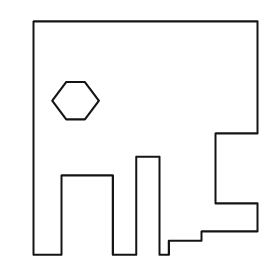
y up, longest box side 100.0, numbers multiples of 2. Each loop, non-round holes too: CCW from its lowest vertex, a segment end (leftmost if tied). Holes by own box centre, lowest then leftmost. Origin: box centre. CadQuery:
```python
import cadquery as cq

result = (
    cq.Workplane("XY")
    .moveTo(-48.0, -50.0)
    .lineTo(-36.0, -50.0)
    .lineTo(-36.0, -16.0)
    .lineTo(-14.0, -16.0)
    .lineTo(-14.0, -50.0)
    .lineTo(-4.0, -50.0)
    .lineTo(-4.0, -8.0)
    .lineTo(6.0, -8.0)
    .lineTo(6.0, -50.0)
    .lineTo(10.0, -50.0)
    .lineTo(10.0, -44.0)
    .lineTo(24.0, -44.0)
    .lineTo(24.0, -40.0)
    .lineTo(48.0, -40.0)
    .lineTo(48.0, -28.0)
    .lineTo(30.0, -28.0)
    .lineTo(30.0, 2.0)
    .lineTo(48.0, 2.0)
    .lineTo(48.0, 50.0)
    .lineTo(-48.0, 50.0)
    .close()
    .moveTo(-34.0, 8.0)
    .lineTo(-26.0, 8.0)
    .lineTo(-20.0, 16.0)
    .lineTo(-26.0, 24.0)
    .lineTo(-34.0, 24.0)
    .lineTo(-40.0, 16.0)
    .close()
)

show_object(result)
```